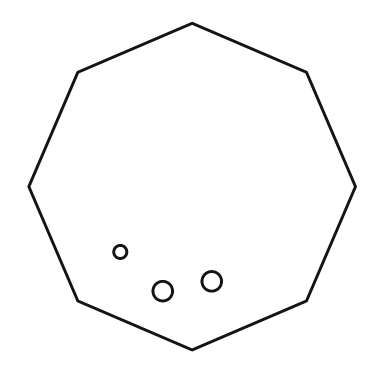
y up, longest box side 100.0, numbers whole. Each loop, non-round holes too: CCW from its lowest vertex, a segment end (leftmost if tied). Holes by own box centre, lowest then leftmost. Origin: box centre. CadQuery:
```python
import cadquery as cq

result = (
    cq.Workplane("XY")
    .moveTo(0.0, -50.0)
    .lineTo(35.0, -35.0)
    .lineTo(50.0, 0.0)
    .lineTo(35.0, 35.0)
    .lineTo(0.0, 50.0)
    .lineTo(-35.0, 35.0)
    .lineTo(-50.0, 0.0)
    .lineTo(-35.0, -35.0)
    .close()
    .moveTo(-9.0, -32.0)
    .circle(3.0)
    .moveTo(6.0, -29.0)
    .circle(3.0)
    .moveTo(-22.0, -20.0)
    .circle(2.0)
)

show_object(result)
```